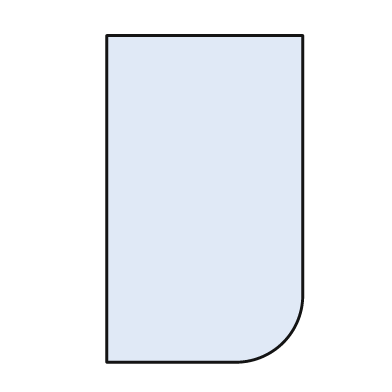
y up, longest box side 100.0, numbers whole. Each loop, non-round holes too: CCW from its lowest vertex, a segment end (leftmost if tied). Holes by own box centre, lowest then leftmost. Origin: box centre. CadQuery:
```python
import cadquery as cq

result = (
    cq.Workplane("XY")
    .moveTo(-30.0, -50.0)
    .lineTo(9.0, -50.0)
    .threePointArc((24.0, -44.0), (30.0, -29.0))
    .lineTo(30.0, 50.0)
    .lineTo(-30.0, 50.0)
    .close()
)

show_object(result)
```